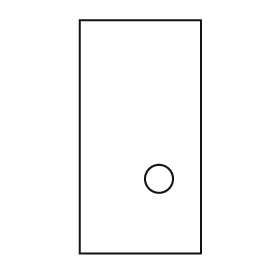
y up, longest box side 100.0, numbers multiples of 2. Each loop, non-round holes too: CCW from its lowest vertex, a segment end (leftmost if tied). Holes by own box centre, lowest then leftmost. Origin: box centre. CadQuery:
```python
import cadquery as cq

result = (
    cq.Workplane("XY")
    .moveTo(-26.0, -50.0)
    .lineTo(26.0, -50.0)
    .lineTo(26.0, 50.0)
    .lineTo(-26.0, 50.0)
    .close()
    .moveTo(8.0, -18.0)
    .circle(6.0)
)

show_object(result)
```